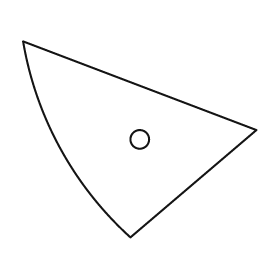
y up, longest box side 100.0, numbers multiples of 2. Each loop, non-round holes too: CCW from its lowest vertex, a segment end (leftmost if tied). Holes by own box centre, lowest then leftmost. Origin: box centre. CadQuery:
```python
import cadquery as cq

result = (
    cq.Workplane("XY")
    .moveTo(-4.0, -42.0)
    .lineTo(50.0, 4.0)
    .lineTo(-50.0, 42.0)
    .threePointArc((-34.0, -4.0), (-4.0, -42.0))
    .close()
    .moveTo(0.0, 0.0)
    .circle(4.0)
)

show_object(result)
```